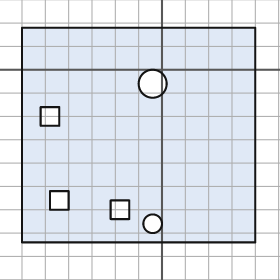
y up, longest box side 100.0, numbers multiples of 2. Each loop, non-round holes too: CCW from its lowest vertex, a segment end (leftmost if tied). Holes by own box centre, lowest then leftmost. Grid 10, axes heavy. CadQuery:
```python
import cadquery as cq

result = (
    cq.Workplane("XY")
    .moveTo(-60.0, -74.0)
    .lineTo(40.0, -74.0)
    .lineTo(40.0, 18.0)
    .lineTo(-60.0, 18.0)
    .close()
    .moveTo(-4.0, -66.0)
    .circle(4.0)
    .moveTo(-22.0, -64.0)
    .lineTo(-14.0, -64.0)
    .lineTo(-14.0, -56.0)
    .lineTo(-22.0, -56.0)
    .close()
    .moveTo(-48.0, -60.0)
    .lineTo(-40.0, -60.0)
    .lineTo(-40.0, -52.0)
    .lineTo(-48.0, -52.0)
    .close()
    .moveTo(-52.0, -24.0)
    .lineTo(-44.0, -24.0)
    .lineTo(-44.0, -16.0)
    .lineTo(-52.0, -16.0)
    .close()
    .moveTo(-4.0, -6.0)
    .circle(6.0)
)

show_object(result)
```